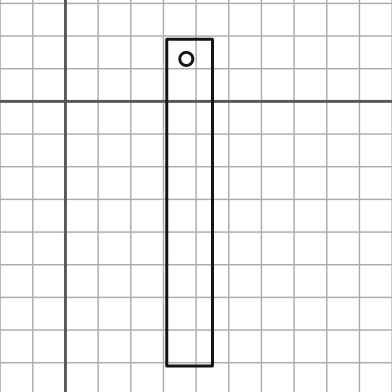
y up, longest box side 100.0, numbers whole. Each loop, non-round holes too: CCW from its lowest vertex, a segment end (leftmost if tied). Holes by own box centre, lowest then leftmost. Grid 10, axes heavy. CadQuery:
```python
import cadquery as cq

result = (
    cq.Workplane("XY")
    .moveTo(31.0, -81.0)
    .lineTo(45.0, -81.0)
    .lineTo(45.0, 19.0)
    .lineTo(31.0, 19.0)
    .close()
    .moveTo(37.0, 13.0)
    .circle(2.0)
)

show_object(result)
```